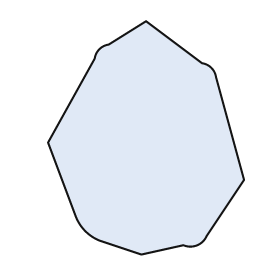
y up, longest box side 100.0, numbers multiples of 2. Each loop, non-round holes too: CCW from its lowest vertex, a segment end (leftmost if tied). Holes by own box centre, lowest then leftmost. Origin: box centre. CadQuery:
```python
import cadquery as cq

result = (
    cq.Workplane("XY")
    .moveTo(-2.0, -50.0)
    .lineTo(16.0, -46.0)
    .threePointArc((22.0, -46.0), (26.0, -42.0))
    .lineTo(42.0, -18.0)
    .lineTo(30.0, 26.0)
    .threePointArc((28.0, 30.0), (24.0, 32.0))
    .lineTo(0.0, 50.0)
    .lineTo(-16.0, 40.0)
    .threePointArc((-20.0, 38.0), (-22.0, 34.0))
    .lineTo(-42.0, -2.0)
    .lineTo(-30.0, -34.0)
    .threePointArc((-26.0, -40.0), (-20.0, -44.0))
    .close()
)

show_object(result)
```